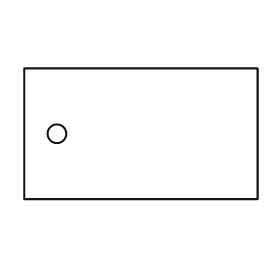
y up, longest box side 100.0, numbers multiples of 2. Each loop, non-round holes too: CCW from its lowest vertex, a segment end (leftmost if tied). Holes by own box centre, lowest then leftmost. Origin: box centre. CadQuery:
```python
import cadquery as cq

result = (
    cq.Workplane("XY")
    .moveTo(-50.0, -28.0)
    .lineTo(50.0, -28.0)
    .lineTo(50.0, 28.0)
    .lineTo(-50.0, 28.0)
    .close()
    .moveTo(-36.0, 0.0)
    .circle(4.0)
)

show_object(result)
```